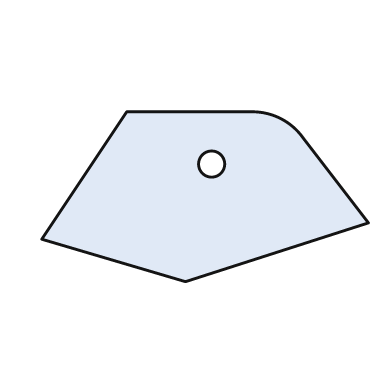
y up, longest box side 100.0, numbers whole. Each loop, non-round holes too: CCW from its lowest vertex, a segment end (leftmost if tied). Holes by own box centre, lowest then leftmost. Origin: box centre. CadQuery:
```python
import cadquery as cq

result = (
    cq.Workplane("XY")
    .moveTo(-6.0, -26.0)
    .lineTo(50.0, -8.0)
    .lineTo(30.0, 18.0)
    .threePointArc((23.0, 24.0), (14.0, 26.0))
    .lineTo(-24.0, 26.0)
    .lineTo(-50.0, -13.0)
    .close()
    .moveTo(2.0, 10.0)
    .circle(4.0)
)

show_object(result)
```